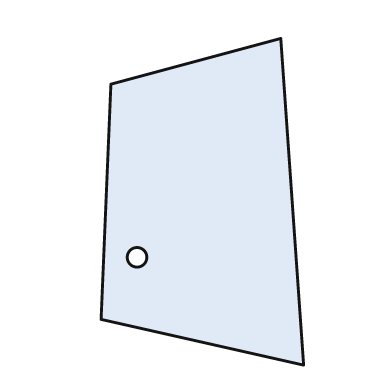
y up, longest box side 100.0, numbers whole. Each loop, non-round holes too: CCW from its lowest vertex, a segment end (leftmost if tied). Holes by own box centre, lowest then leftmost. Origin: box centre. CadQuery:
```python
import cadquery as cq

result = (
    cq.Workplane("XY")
    .moveTo(31.0, -50.0)
    .lineTo(24.0, 50.0)
    .lineTo(-28.0, 36.0)
    .lineTo(-31.0, -36.0)
    .close()
    .moveTo(-20.0, -17.0)
    .circle(3.0)
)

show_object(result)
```